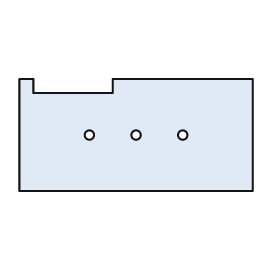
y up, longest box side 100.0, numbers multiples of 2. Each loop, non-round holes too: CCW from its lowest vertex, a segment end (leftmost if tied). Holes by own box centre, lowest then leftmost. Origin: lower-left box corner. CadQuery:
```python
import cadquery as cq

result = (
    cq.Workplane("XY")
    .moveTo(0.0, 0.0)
    .lineTo(100.0, 0.0)
    .lineTo(100.0, 48.0)
    .lineTo(40.0, 48.0)
    .lineTo(40.0, 42.0)
    .lineTo(6.0, 42.0)
    .lineTo(6.0, 48.0)
    .lineTo(0.0, 48.0)
    .close()
    .moveTo(30.0, 24.0)
    .circle(2.0)
    .moveTo(50.0, 24.0)
    .circle(2.0)
    .moveTo(70.0, 24.0)
    .circle(2.0)
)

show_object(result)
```